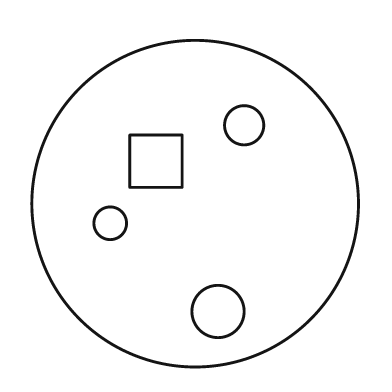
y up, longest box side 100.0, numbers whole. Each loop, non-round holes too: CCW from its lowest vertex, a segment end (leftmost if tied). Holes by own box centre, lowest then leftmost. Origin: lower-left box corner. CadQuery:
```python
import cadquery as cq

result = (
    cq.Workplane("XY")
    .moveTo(50.0, 50.0)
    .circle(50.0)
    .moveTo(57.0, 17.0)
    .circle(8.0)
    .moveTo(24.0, 44.0)
    .circle(5.0)
    .moveTo(30.0, 55.0)
    .lineTo(46.0, 55.0)
    .lineTo(46.0, 71.0)
    .lineTo(30.0, 71.0)
    .close()
    .moveTo(65.0, 74.0)
    .circle(6.0)
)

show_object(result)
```